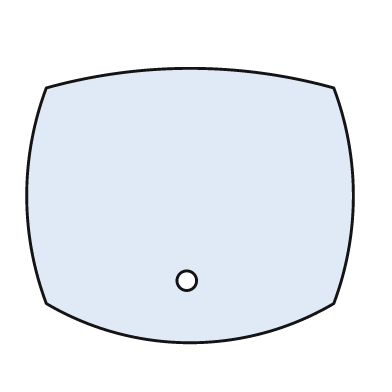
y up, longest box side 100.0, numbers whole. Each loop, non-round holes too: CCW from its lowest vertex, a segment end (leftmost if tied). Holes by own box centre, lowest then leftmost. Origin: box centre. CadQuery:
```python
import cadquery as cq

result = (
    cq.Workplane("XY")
    .moveTo(-44.0, -30.0)
    .threePointArc((0.0, -42.0), (44.0, -30.0))
    .threePointArc((50.0, 3.0), (44.0, 36.0))
    .threePointArc((0.0, 42.0), (-44.0, 36.0))
    .threePointArc((-50.0, 3.0), (-44.0, -30.0))
    .close()
    .moveTo(-1.0, -23.0)
    .circle(3.0)
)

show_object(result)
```